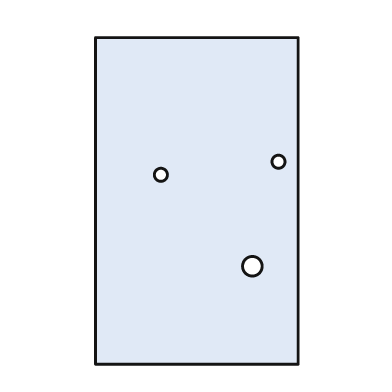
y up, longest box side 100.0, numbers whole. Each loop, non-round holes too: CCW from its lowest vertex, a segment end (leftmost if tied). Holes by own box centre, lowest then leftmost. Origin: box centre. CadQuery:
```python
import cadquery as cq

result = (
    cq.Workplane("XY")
    .moveTo(-31.0, -50.0)
    .lineTo(31.0, -50.0)
    .lineTo(31.0, 50.0)
    .lineTo(-31.0, 50.0)
    .close()
    .moveTo(17.0, -20.0)
    .circle(3.0)
    .moveTo(-11.0, 8.0)
    .circle(2.0)
    .moveTo(25.0, 12.0)
    .circle(2.0)
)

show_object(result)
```